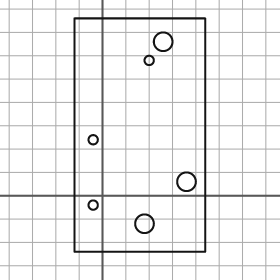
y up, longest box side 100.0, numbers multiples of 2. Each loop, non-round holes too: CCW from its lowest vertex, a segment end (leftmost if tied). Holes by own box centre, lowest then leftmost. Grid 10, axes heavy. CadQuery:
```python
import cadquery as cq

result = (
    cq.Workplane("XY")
    .moveTo(-12.0, -24.0)
    .lineTo(44.0, -24.0)
    .lineTo(44.0, 76.0)
    .lineTo(-12.0, 76.0)
    .close()
    .moveTo(18.0, -12.0)
    .circle(4.0)
    .moveTo(-4.0, -4.0)
    .circle(2.0)
    .moveTo(36.0, 6.0)
    .circle(4.0)
    .moveTo(-4.0, 24.0)
    .circle(2.0)
    .moveTo(20.0, 58.0)
    .circle(2.0)
    .moveTo(26.0, 66.0)
    .circle(4.0)
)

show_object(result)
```